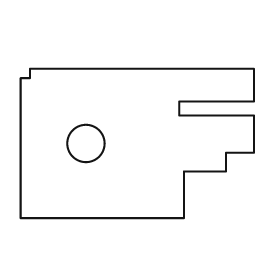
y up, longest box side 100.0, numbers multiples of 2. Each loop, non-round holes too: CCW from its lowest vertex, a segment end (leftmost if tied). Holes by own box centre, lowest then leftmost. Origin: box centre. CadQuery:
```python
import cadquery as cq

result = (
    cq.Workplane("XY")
    .moveTo(-50.0, -32.0)
    .lineTo(20.0, -32.0)
    .lineTo(20.0, -12.0)
    .lineTo(38.0, -12.0)
    .lineTo(38.0, -4.0)
    .lineTo(50.0, -4.0)
    .lineTo(50.0, 12.0)
    .lineTo(18.0, 12.0)
    .lineTo(18.0, 18.0)
    .lineTo(50.0, 18.0)
    .lineTo(50.0, 32.0)
    .lineTo(-46.0, 32.0)
    .lineTo(-46.0, 28.0)
    .lineTo(-50.0, 28.0)
    .close()
    .moveTo(-22.0, 0.0)
    .circle(8.0)
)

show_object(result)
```